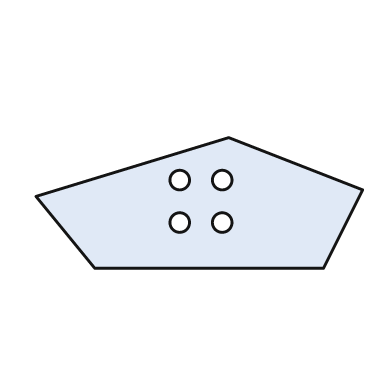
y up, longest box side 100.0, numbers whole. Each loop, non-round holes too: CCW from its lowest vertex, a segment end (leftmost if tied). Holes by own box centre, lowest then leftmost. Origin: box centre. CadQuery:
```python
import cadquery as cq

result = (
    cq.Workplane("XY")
    .moveTo(-32.0, -20.0)
    .lineTo(38.0, -20.0)
    .lineTo(50.0, 4.0)
    .lineTo(9.0, 20.0)
    .lineTo(-50.0, 2.0)
    .close()
    .moveTo(-6.0, -6.0)
    .circle(3.0)
    .moveTo(7.0, -6.0)
    .circle(3.0)
    .moveTo(-6.0, 7.0)
    .circle(3.0)
    .moveTo(7.0, 7.0)
    .circle(3.0)
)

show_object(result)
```